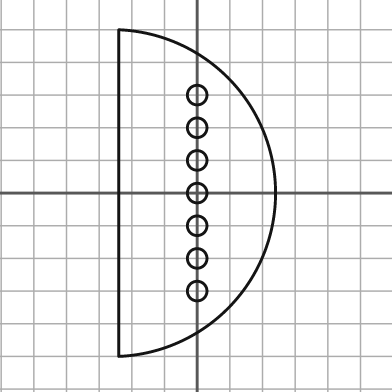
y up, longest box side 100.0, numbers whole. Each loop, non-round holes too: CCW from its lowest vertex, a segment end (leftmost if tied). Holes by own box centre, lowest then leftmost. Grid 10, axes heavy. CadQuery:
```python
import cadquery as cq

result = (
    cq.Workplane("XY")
    .moveTo(-24.0, -50.0)
    .threePointArc((24.0, 0.0), (-24.0, 50.0))
    .close()
    .moveTo(0.0, -30.0)
    .circle(3.0)
    .moveTo(0.0, -20.0)
    .circle(3.0)
    .moveTo(0.0, -10.0)
    .circle(3.0)
    .moveTo(0.0, 0.0)
    .circle(3.0)
    .moveTo(0.0, 10.0)
    .circle(3.0)
    .moveTo(0.0, 20.0)
    .circle(3.0)
    .moveTo(0.0, 30.0)
    .circle(3.0)
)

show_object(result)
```